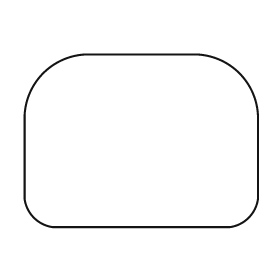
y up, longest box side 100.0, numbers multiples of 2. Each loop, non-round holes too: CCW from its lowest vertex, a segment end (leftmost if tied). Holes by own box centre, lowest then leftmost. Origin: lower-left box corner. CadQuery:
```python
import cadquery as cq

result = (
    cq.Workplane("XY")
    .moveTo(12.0, 0.0)
    .lineTo(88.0, 0.0)
    .threePointArc((96.0, 4.0), (100.0, 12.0))
    .lineTo(100.0, 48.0)
    .threePointArc((92.0, 66.0), (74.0, 74.0))
    .lineTo(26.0, 74.0)
    .threePointArc((8.0, 66.0), (0.0, 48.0))
    .lineTo(0.0, 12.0)
    .threePointArc((4.0, 4.0), (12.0, 0.0))
    .close()
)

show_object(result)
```